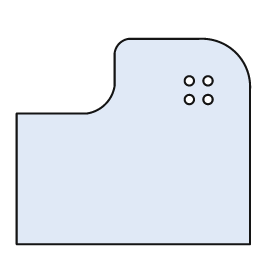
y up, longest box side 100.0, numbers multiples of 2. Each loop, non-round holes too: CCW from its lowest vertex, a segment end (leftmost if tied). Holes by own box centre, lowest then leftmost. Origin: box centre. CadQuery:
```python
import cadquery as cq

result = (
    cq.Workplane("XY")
    .moveTo(-50.0, -44.0)
    .lineTo(50.0, -44.0)
    .lineTo(50.0, 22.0)
    .threePointArc((44.0, 38.0), (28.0, 44.0))
    .lineTo(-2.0, 44.0)
    .threePointArc((-6.0, 42.0), (-8.0, 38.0))
    .lineTo(-8.0, 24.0)
    .threePointArc((-12.0, 16.0), (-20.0, 12.0))
    .lineTo(-50.0, 12.0)
    .close()
    .moveTo(24.0, 18.0)
    .circle(2.0)
    .moveTo(32.0, 18.0)
    .circle(2.0)
    .moveTo(24.0, 26.0)
    .circle(2.0)
    .moveTo(32.0, 26.0)
    .circle(2.0)
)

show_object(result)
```